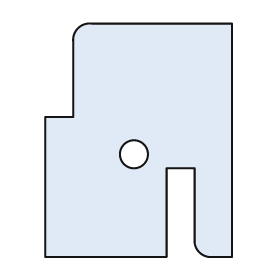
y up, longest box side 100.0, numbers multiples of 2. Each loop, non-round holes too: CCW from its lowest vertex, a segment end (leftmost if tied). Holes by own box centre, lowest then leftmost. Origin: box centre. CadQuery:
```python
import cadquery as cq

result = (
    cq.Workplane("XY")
    .moveTo(-40.0, -50.0)
    .lineTo(12.0, -50.0)
    .lineTo(12.0, -12.0)
    .lineTo(24.0, -12.0)
    .lineTo(24.0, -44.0)
    .threePointArc((26.0, -48.0), (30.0, -50.0))
    .lineTo(40.0, -50.0)
    .lineTo(40.0, 50.0)
    .lineTo(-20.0, 50.0)
    .threePointArc((-26.0, 48.0), (-28.0, 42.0))
    .lineTo(-28.0, 10.0)
    .lineTo(-40.0, 10.0)
    .close()
    .moveTo(-2.0, -6.0)
    .circle(6.0)
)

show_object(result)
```